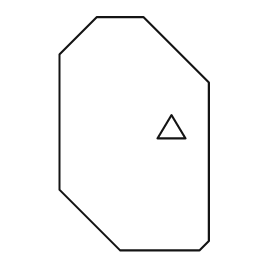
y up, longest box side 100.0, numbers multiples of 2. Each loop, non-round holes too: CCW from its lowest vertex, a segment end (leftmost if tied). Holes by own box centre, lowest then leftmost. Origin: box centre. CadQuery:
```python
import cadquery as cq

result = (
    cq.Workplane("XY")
    .moveTo(-6.0, -50.0)
    .lineTo(28.0, -50.0)
    .lineTo(32.0, -46.0)
    .lineTo(32.0, 22.0)
    .lineTo(4.0, 50.0)
    .lineTo(-16.0, 50.0)
    .lineTo(-32.0, 34.0)
    .lineTo(-32.0, -24.0)
    .close()
    .moveTo(10.0, -2.0)
    .lineTo(22.0, -2.0)
    .lineTo(16.0, 8.0)
    .close()
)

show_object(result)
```